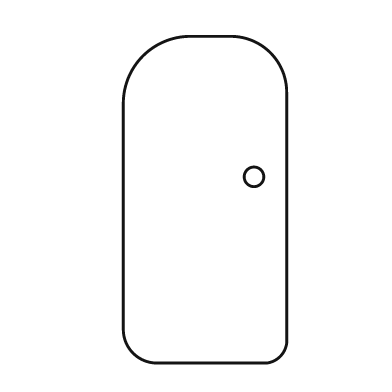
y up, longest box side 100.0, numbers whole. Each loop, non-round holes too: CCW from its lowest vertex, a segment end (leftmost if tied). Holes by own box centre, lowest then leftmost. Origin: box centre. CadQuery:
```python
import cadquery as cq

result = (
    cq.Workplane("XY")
    .moveTo(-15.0, -50.0)
    .lineTo(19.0, -50.0)
    .threePointArc((23.0, -48.0), (25.0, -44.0))
    .lineTo(25.0, 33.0)
    .threePointArc((20.0, 45.0), (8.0, 50.0))
    .lineTo(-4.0, 50.0)
    .threePointArc((-19.0, 44.0), (-25.0, 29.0))
    .lineTo(-25.0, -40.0)
    .threePointArc((-22.0, -47.0), (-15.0, -50.0))
    .close()
    .moveTo(15.0, 7.0)
    .circle(3.0)
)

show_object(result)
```